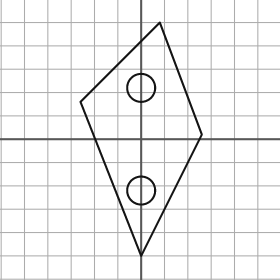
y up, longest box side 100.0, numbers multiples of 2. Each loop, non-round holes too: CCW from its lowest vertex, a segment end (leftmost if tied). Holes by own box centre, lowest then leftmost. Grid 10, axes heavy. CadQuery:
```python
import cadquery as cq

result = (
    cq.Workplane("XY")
    .moveTo(0.0, -50.0)
    .lineTo(26.0, 2.0)
    .lineTo(8.0, 50.0)
    .lineTo(-26.0, 16.0)
    .close()
    .moveTo(0.0, -22.0)
    .circle(6.0)
    .moveTo(0.0, 22.0)
    .circle(6.0)
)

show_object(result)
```